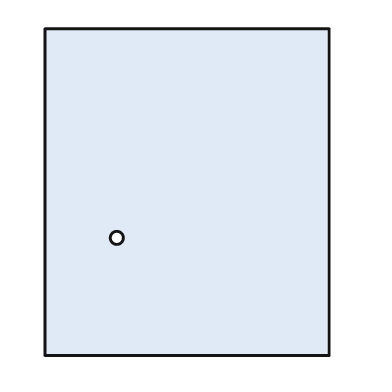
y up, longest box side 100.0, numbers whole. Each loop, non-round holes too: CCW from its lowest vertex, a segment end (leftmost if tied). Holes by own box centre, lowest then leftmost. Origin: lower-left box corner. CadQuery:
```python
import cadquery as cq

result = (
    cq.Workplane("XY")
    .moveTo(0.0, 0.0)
    .lineTo(87.0, 0.0)
    .lineTo(87.0, 100.0)
    .lineTo(0.0, 100.0)
    .close()
    .moveTo(22.0, 36.0)
    .circle(2.0)
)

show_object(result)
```